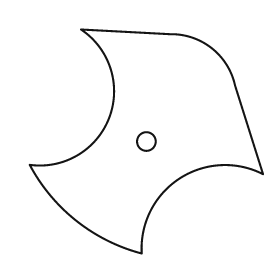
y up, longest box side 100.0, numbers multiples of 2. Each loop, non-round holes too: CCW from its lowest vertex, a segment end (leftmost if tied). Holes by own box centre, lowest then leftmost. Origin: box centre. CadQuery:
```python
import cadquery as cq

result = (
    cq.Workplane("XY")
    .moveTo(-2.0, -48.0)
    .threePointArc((14.0, -16.0), (50.0, -14.0))
    .lineTo(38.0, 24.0)
    .threePointArc((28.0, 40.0), (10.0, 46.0))
    .lineTo(-28.0, 48.0)
    .threePointArc((-16.0, 10.0), (-50.0, -10.0))
    .threePointArc((-30.0, -34.0), (-2.0, -48.0))
    .close()
    .moveTo(0.0, 0.0)
    .circle(4.0)
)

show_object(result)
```